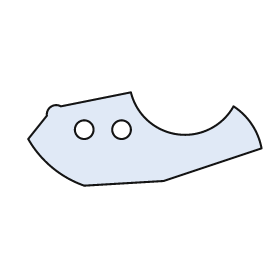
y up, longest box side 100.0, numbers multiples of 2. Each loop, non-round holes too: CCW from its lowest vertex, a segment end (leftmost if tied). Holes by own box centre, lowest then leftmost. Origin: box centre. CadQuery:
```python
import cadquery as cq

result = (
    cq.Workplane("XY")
    .moveTo(-26.0, -20.0)
    .lineTo(8.0, -18.0)
    .lineTo(50.0, -4.0)
    .threePointArc((46.0, 6.0), (38.0, 14.0))
    .threePointArc((14.0, 2.0), (-6.0, 20.0))
    .lineTo(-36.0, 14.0)
    .threePointArc((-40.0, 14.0), (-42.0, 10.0))
    .lineTo(-50.0, 0.0)
    .threePointArc((-40.0, -12.0), (-26.0, -20.0))
    .close()
    .moveTo(-26.0, 4.0)
    .circle(4.0)
    .moveTo(-10.0, 4.0)
    .circle(4.0)
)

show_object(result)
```